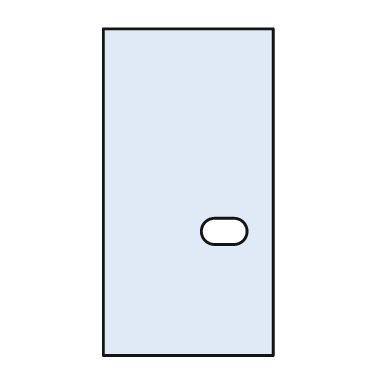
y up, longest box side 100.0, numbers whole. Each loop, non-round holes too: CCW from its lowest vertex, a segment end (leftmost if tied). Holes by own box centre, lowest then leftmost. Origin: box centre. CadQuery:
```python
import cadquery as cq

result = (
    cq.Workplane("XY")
    .moveTo(-26.0, -50.0)
    .lineTo(26.0, -50.0)
    .lineTo(26.0, 50.0)
    .lineTo(-26.0, 50.0)
    .close()
    .moveTo(8.0, -16.0)
    .lineTo(14.0, -16.0)
    .threePointArc((18.0, -12.0), (14.0, -8.0))
    .lineTo(8.0, -8.0)
    .threePointArc((4.0, -12.0), (8.0, -16.0))
    .close()
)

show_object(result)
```